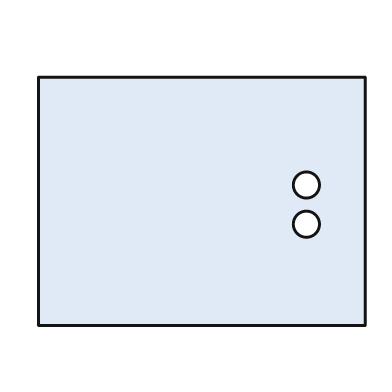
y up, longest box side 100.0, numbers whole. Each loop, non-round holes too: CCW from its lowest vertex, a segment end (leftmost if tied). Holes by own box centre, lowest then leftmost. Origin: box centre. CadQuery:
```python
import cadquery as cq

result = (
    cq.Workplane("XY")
    .moveTo(-50.0, -38.0)
    .lineTo(50.0, -38.0)
    .lineTo(50.0, 38.0)
    .lineTo(-50.0, 38.0)
    .close()
    .moveTo(32.0, -7.0)
    .circle(4.0)
    .moveTo(32.0, 5.0)
    .circle(4.0)
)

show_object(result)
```